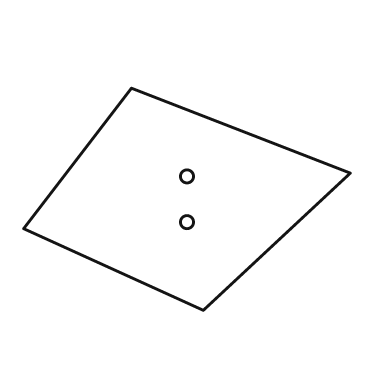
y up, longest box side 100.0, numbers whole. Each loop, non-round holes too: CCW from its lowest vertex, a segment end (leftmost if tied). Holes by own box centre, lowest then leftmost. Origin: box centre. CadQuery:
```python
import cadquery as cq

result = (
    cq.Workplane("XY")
    .moveTo(5.0, -34.0)
    .lineTo(50.0, 8.0)
    .lineTo(-17.0, 34.0)
    .lineTo(-50.0, -9.0)
    .close()
    .moveTo(0.0, -7.0)
    .circle(2.0)
    .moveTo(0.0, 7.0)
    .circle(2.0)
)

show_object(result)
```